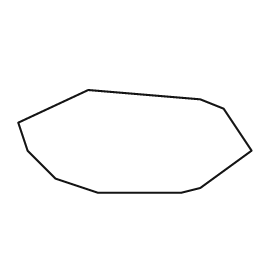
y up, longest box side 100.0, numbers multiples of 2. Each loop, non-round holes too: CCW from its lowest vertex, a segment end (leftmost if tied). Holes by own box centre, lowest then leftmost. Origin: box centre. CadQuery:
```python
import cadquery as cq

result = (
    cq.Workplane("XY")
    .moveTo(-16.0, -22.0)
    .lineTo(20.0, -22.0)
    .lineTo(28.0, -20.0)
    .lineTo(50.0, -4.0)
    .lineTo(38.0, 14.0)
    .lineTo(28.0, 18.0)
    .lineTo(-20.0, 22.0)
    .lineTo(-50.0, 8.0)
    .lineTo(-46.0, -4.0)
    .lineTo(-34.0, -16.0)
    .close()
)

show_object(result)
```